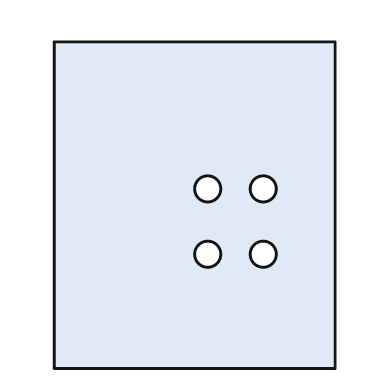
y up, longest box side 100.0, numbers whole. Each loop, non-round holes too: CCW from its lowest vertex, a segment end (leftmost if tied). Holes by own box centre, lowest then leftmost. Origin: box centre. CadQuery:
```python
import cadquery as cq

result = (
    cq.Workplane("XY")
    .moveTo(-43.0, -50.0)
    .lineTo(43.0, -50.0)
    .lineTo(43.0, 50.0)
    .lineTo(-43.0, 50.0)
    .close()
    .moveTo(4.0, -15.0)
    .circle(4.0)
    .moveTo(21.0, -15.0)
    .circle(4.0)
    .moveTo(4.0, 5.0)
    .circle(4.0)
    .moveTo(21.0, 5.0)
    .circle(4.0)
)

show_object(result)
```